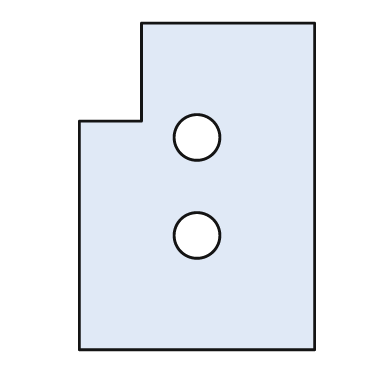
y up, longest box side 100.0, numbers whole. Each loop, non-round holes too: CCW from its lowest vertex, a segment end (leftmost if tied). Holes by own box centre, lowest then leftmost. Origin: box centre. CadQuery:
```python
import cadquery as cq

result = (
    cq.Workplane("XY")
    .moveTo(-36.0, -50.0)
    .lineTo(36.0, -50.0)
    .lineTo(36.0, 50.0)
    .lineTo(-17.0, 50.0)
    .lineTo(-17.0, 20.0)
    .lineTo(-36.0, 20.0)
    .close()
    .moveTo(0.0, -15.0)
    .circle(7.0)
    .moveTo(0.0, 15.0)
    .circle(7.0)
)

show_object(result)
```